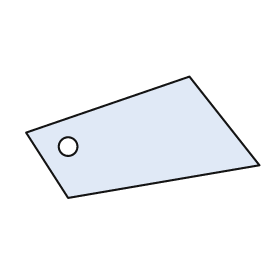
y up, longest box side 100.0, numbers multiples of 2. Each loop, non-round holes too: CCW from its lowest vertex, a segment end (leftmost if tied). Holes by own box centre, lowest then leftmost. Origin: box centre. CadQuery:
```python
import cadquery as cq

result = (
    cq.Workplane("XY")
    .moveTo(-32.0, -26.0)
    .lineTo(50.0, -12.0)
    .lineTo(20.0, 26.0)
    .lineTo(-50.0, 2.0)
    .close()
    .moveTo(-32.0, -4.0)
    .circle(4.0)
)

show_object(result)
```